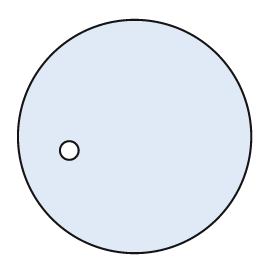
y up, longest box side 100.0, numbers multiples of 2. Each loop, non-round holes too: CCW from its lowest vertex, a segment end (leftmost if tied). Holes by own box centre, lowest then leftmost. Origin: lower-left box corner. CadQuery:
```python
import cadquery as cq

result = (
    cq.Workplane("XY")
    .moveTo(50.0, 50.0)
    .circle(50.0)
    .moveTo(22.0, 44.0)
    .circle(4.0)
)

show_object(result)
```